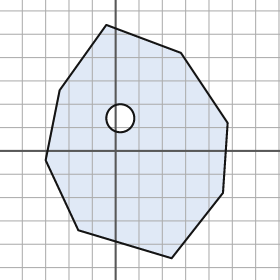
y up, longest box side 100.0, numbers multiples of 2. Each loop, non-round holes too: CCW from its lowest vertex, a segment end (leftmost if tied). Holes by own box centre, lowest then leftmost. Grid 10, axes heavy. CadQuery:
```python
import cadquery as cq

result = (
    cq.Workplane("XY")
    .moveTo(24.0, -46.0)
    .lineTo(46.0, -18.0)
    .lineTo(48.0, 12.0)
    .lineTo(28.0, 42.0)
    .lineTo(-4.0, 54.0)
    .lineTo(-24.0, 26.0)
    .lineTo(-30.0, -4.0)
    .lineTo(-16.0, -34.0)
    .close()
    .moveTo(2.0, 14.0)
    .circle(6.0)
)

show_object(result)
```